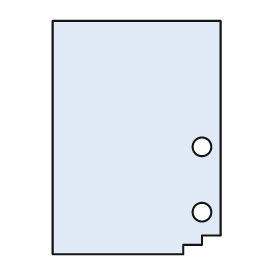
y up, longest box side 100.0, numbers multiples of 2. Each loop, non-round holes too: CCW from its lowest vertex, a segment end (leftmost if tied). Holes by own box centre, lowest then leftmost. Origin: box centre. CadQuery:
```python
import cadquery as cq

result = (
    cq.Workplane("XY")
    .moveTo(-36.0, -50.0)
    .lineTo(20.0, -50.0)
    .lineTo(20.0, -46.0)
    .lineTo(28.0, -46.0)
    .lineTo(28.0, -42.0)
    .lineTo(36.0, -42.0)
    .lineTo(36.0, 50.0)
    .lineTo(-36.0, 50.0)
    .close()
    .moveTo(28.0, -32.0)
    .circle(4.0)
    .moveTo(28.0, -4.0)
    .circle(4.0)
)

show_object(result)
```